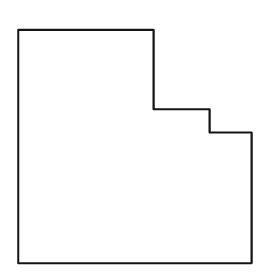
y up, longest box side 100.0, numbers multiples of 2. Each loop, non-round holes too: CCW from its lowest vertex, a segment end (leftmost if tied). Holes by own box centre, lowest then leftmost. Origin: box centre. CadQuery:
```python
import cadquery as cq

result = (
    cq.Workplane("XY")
    .moveTo(-50.0, -50.0)
    .lineTo(50.0, -50.0)
    .lineTo(50.0, 6.0)
    .lineTo(32.0, 6.0)
    .lineTo(32.0, 16.0)
    .lineTo(8.0, 16.0)
    .lineTo(8.0, 50.0)
    .lineTo(-50.0, 50.0)
    .close()
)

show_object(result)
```